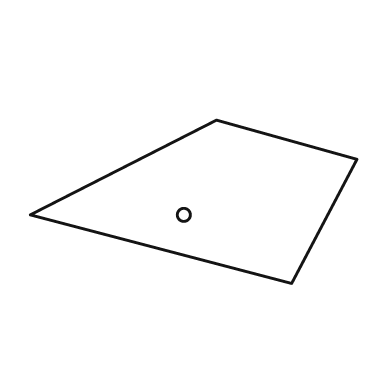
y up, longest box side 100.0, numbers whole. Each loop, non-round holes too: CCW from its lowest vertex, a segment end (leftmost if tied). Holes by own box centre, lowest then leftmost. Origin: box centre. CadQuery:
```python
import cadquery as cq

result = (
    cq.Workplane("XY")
    .moveTo(30.0, -25.0)
    .lineTo(50.0, 13.0)
    .lineTo(7.0, 25.0)
    .lineTo(-50.0, -4.0)
    .close()
    .moveTo(-3.0, -4.0)
    .circle(2.0)
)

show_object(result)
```